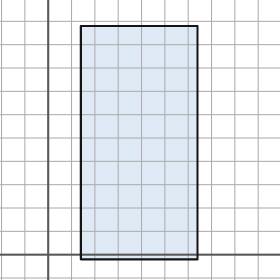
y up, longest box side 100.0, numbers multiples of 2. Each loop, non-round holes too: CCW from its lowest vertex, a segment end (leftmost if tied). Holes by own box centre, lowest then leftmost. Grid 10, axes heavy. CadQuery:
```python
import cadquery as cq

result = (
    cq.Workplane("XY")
    .moveTo(14.0, -2.0)
    .lineTo(64.0, -2.0)
    .lineTo(64.0, 98.0)
    .lineTo(14.0, 98.0)
    .close()
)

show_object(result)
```